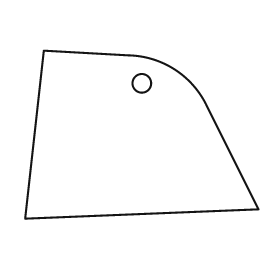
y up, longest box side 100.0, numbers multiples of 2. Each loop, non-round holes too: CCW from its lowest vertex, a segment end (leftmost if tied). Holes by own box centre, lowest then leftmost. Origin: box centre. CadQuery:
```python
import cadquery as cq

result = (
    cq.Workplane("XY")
    .moveTo(-50.0, -36.0)
    .lineTo(50.0, -32.0)
    .lineTo(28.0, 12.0)
    .threePointArc((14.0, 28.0), (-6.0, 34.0))
    .lineTo(-42.0, 36.0)
    .close()
    .moveTo(0.0, 22.0)
    .circle(4.0)
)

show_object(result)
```